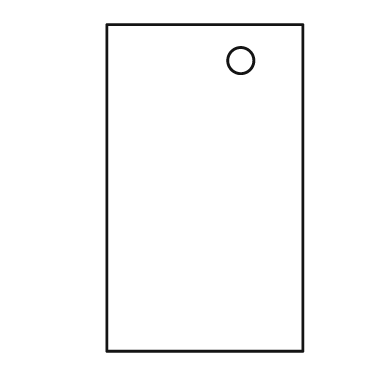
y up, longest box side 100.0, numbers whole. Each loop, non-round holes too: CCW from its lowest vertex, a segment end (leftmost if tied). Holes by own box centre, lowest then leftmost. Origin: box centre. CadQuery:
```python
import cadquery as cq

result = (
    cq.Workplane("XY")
    .moveTo(-30.0, -50.0)
    .lineTo(30.0, -50.0)
    .lineTo(30.0, 50.0)
    .lineTo(-30.0, 50.0)
    .close()
    .moveTo(11.0, 39.0)
    .circle(4.0)
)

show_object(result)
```